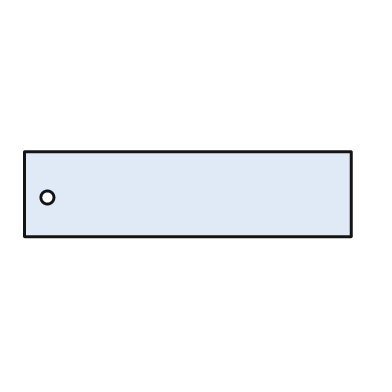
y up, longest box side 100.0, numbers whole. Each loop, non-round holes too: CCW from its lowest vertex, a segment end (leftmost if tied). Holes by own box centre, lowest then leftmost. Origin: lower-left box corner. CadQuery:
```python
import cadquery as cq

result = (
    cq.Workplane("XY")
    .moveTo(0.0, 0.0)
    .lineTo(100.0, 0.0)
    .lineTo(100.0, 26.0)
    .lineTo(0.0, 26.0)
    .close()
    .moveTo(7.0, 12.0)
    .circle(2.0)
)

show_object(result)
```